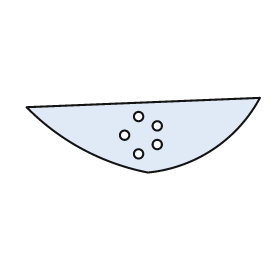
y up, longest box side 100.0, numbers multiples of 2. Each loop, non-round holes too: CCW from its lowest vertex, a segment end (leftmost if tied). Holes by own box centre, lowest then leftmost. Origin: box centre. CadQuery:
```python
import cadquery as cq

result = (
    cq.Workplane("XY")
    .moveTo(2.0, -16.0)
    .threePointArc((30.0, -6.0), (50.0, 16.0))
    .lineTo(-50.0, 12.0)
    .threePointArc((-26.0, -6.0), (2.0, -16.0))
    .close()
    .moveTo(-2.0, -8.0)
    .circle(2.0)
    .moveTo(6.0, -4.0)
    .circle(2.0)
    .moveTo(-8.0, 0.0)
    .circle(2.0)
    .moveTo(6.0, 4.0)
    .circle(2.0)
    .moveTo(-2.0, 8.0)
    .circle(2.0)
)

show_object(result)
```